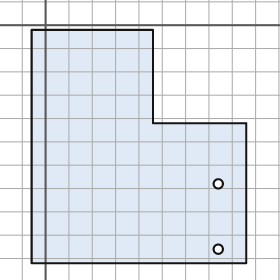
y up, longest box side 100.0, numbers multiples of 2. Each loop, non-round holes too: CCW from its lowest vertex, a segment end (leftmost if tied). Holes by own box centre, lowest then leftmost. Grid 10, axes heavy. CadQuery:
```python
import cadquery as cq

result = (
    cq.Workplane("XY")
    .moveTo(-6.0, -102.0)
    .lineTo(86.0, -102.0)
    .lineTo(86.0, -42.0)
    .lineTo(46.0, -42.0)
    .lineTo(46.0, -2.0)
    .lineTo(-6.0, -2.0)
    .close()
    .moveTo(74.0, -96.0)
    .circle(2.0)
    .moveTo(74.0, -68.0)
    .circle(2.0)
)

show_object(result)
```